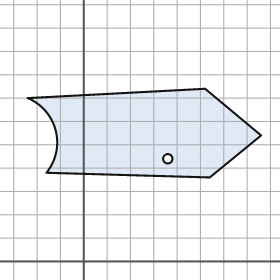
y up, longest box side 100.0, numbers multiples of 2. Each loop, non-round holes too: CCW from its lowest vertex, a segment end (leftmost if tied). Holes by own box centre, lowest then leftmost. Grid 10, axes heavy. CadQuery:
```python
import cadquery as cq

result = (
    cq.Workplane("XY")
    .moveTo(54.0, 36.0)
    .lineTo(76.0, 54.0)
    .lineTo(52.0, 74.0)
    .lineTo(-24.0, 70.0)
    .threePointArc((-12.0, 56.0), (-16.0, 38.0))
    .close()
    .moveTo(36.0, 44.0)
    .circle(2.0)
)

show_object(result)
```